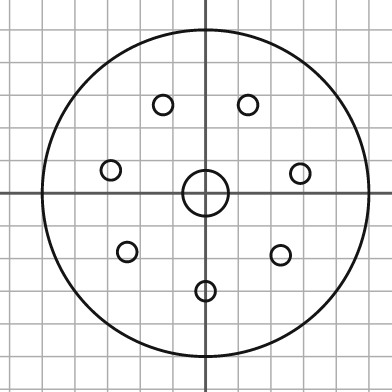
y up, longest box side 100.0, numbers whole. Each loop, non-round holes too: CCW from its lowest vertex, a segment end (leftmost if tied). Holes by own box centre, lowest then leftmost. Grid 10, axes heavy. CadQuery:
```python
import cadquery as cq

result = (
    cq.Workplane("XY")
    .moveTo(0.0, 0.0)
    .circle(50.0)
    .moveTo(0.0, -30.0)
    .circle(3.0)
    .moveTo(23.0, -19.0)
    .circle(3.0)
    .moveTo(-24.0, -18.0)
    .circle(3.0)
    .moveTo(0.0, 0.0)
    .circle(7.0)
    .moveTo(29.0, 6.0)
    .circle(3.0)
    .moveTo(-29.0, 7.0)
    .circle(3.0)
    .moveTo(-13.0, 27.0)
    .circle(3.0)
    .moveTo(13.0, 27.0)
    .circle(3.0)
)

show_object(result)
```